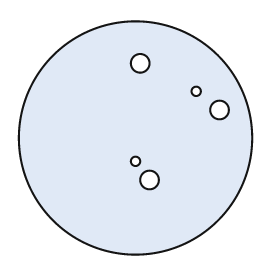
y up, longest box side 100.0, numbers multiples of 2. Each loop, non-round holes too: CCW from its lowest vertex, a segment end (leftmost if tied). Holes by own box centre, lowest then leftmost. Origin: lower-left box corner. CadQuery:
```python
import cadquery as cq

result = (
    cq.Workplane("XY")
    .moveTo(50.0, 50.0)
    .circle(50.0)
    .moveTo(56.0, 32.0)
    .circle(4.0)
    .moveTo(50.0, 40.0)
    .circle(2.0)
    .moveTo(86.0, 62.0)
    .circle(4.0)
    .moveTo(76.0, 70.0)
    .circle(2.0)
    .moveTo(52.0, 82.0)
    .circle(4.0)
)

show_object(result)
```